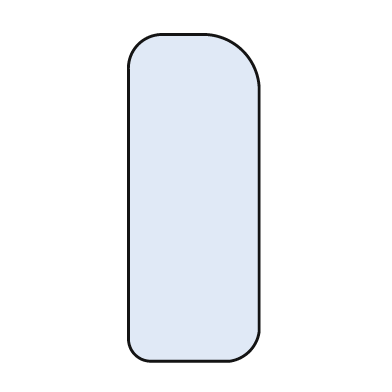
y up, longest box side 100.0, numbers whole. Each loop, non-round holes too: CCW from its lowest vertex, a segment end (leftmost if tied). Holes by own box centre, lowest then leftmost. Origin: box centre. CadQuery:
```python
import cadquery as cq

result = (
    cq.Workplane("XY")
    .moveTo(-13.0, -50.0)
    .lineTo(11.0, -50.0)
    .threePointArc((17.0, -47.0), (20.0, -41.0))
    .lineTo(20.0, 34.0)
    .threePointArc((15.0, 45.0), (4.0, 50.0))
    .lineTo(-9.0, 50.0)
    .threePointArc((-17.0, 47.0), (-20.0, 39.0))
    .lineTo(-20.0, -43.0)
    .threePointArc((-18.0, -48.0), (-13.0, -50.0))
    .close()
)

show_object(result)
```